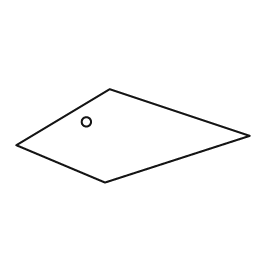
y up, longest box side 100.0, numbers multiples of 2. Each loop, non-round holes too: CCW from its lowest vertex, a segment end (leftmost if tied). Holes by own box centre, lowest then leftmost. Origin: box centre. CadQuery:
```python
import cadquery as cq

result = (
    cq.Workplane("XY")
    .moveTo(-12.0, -20.0)
    .lineTo(50.0, 0.0)
    .lineTo(-10.0, 20.0)
    .lineTo(-50.0, -4.0)
    .close()
    .moveTo(-20.0, 6.0)
    .circle(2.0)
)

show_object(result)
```